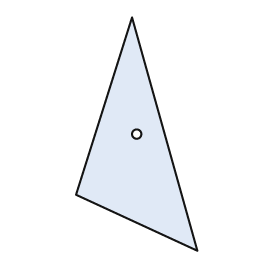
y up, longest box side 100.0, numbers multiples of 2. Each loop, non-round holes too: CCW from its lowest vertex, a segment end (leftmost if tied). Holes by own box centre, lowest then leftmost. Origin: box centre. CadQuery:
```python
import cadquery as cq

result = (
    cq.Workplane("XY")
    .moveTo(26.0, -50.0)
    .lineTo(-2.0, 50.0)
    .lineTo(-26.0, -26.0)
    .close()
    .moveTo(0.0, 0.0)
    .circle(2.0)
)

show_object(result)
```